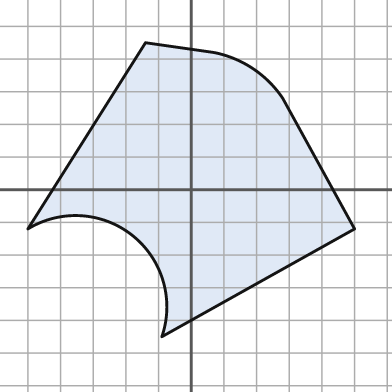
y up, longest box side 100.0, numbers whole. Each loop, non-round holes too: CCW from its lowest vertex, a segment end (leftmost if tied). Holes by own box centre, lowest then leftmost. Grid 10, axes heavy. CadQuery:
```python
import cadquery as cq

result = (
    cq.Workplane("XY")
    .moveTo(-9.0, -45.0)
    .lineTo(50.0, -12.0)
    .lineTo(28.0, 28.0)
    .threePointArc((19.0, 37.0), (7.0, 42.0))
    .lineTo(-14.0, 45.0)
    .lineTo(-50.0, -12.0)
    .threePointArc((-18.0, -14.0), (-9.0, -45.0))
    .close()
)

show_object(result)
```